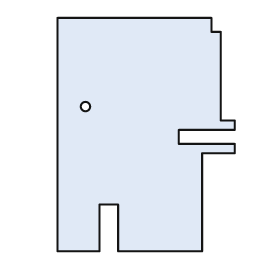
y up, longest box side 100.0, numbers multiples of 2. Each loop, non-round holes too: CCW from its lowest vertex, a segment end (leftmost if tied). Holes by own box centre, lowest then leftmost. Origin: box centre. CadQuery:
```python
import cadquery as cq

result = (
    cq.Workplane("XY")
    .moveTo(-38.0, -50.0)
    .lineTo(-20.0, -50.0)
    .lineTo(-20.0, -30.0)
    .lineTo(-12.0, -30.0)
    .lineTo(-12.0, -50.0)
    .lineTo(24.0, -50.0)
    .lineTo(24.0, -8.0)
    .lineTo(38.0, -8.0)
    .lineTo(38.0, -4.0)
    .lineTo(14.0, -4.0)
    .lineTo(14.0, 2.0)
    .lineTo(38.0, 2.0)
    .lineTo(38.0, 6.0)
    .lineTo(32.0, 6.0)
    .lineTo(32.0, 44.0)
    .lineTo(28.0, 44.0)
    .lineTo(28.0, 50.0)
    .lineTo(-38.0, 50.0)
    .close()
    .moveTo(-26.0, 12.0)
    .circle(2.0)
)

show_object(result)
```